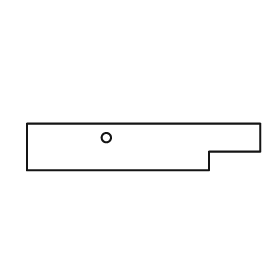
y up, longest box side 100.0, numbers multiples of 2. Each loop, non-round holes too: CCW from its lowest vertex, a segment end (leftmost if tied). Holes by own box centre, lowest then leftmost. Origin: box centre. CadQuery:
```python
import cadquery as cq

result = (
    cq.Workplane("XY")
    .moveTo(-50.0, -10.0)
    .lineTo(28.0, -10.0)
    .lineTo(28.0, -2.0)
    .lineTo(50.0, -2.0)
    .lineTo(50.0, 10.0)
    .lineTo(-50.0, 10.0)
    .close()
    .moveTo(-16.0, 4.0)
    .circle(2.0)
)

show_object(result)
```